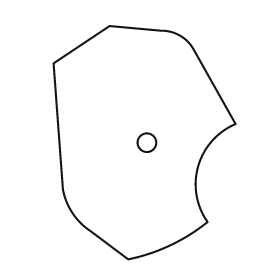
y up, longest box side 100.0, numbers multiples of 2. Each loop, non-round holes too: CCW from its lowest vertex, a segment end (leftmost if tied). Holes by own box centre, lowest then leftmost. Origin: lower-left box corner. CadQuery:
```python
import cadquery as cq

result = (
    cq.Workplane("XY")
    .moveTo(32.0, 0.0)
    .threePointArc((50.0, 6.0), (66.0, 16.0))
    .threePointArc((62.0, 40.0), (78.0, 58.0))
    .lineTo(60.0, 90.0)
    .threePointArc((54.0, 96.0), (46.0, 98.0))
    .lineTo(24.0, 100.0)
    .lineTo(0.0, 84.0)
    .lineTo(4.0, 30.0)
    .threePointArc((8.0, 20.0), (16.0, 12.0))
    .close()
    .moveTo(40.0, 50.0)
    .circle(4.0)
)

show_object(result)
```